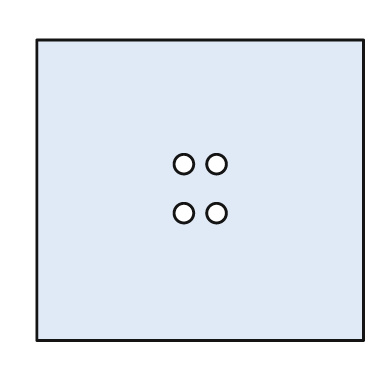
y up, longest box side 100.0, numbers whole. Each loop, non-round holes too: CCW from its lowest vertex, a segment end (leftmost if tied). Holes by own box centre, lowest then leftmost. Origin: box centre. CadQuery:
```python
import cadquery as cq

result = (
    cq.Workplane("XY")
    .moveTo(-50.0, -46.0)
    .lineTo(50.0, -46.0)
    .lineTo(50.0, 46.0)
    .lineTo(-50.0, 46.0)
    .close()
    .moveTo(-5.0, -7.0)
    .circle(3.0)
    .moveTo(5.0, -7.0)
    .circle(3.0)
    .moveTo(-5.0, 8.0)
    .circle(3.0)
    .moveTo(5.0, 8.0)
    .circle(3.0)
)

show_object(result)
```